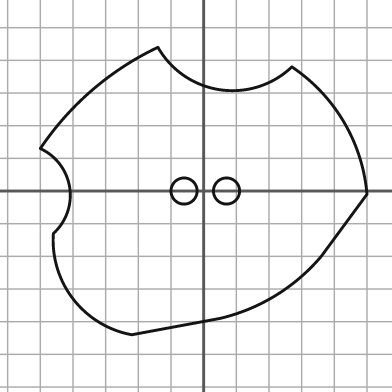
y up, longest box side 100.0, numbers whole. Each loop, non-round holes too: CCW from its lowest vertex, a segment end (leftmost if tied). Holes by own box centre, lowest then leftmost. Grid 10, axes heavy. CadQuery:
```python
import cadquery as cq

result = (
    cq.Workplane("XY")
    .moveTo(-22.0, -44.0)
    .lineTo(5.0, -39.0)
    .threePointArc((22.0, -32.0), (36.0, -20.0))
    .lineTo(50.0, -1.0)
    .threePointArc((43.0, 21.0), (27.0, 38.0))
    .threePointArc((5.0, 31.0), (-14.0, 44.0))
    .threePointArc((-34.0, 31.0), (-50.0, 13.0))
    .threePointArc((-41.0, 1.0), (-46.0, -13.0))
    .threePointArc((-40.0, -33.0), (-22.0, -44.0))
    .close()
    .moveTo(-6.0, 0.0)
    .circle(4.0)
    .moveTo(7.0, 0.0)
    .circle(4.0)
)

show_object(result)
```